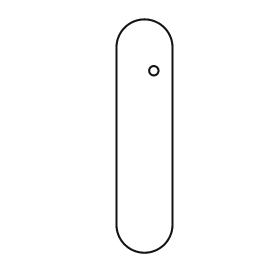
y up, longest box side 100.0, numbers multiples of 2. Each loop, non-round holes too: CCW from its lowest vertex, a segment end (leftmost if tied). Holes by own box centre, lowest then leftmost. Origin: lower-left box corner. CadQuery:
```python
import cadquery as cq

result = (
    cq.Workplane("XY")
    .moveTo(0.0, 12.0)
    .threePointArc((12.0, 0.0), (24.0, 12.0))
    .lineTo(24.0, 88.0)
    .threePointArc((12.0, 100.0), (0.0, 88.0))
    .close()
    .moveTo(16.0, 78.0)
    .circle(2.0)
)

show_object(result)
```